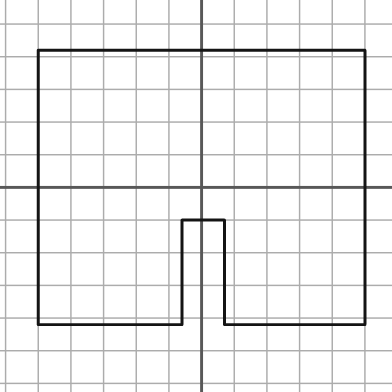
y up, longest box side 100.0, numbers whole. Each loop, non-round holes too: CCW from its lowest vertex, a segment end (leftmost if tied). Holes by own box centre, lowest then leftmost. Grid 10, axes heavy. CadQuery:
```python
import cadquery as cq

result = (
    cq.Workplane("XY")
    .moveTo(-50.0, -42.0)
    .lineTo(-6.0, -42.0)
    .lineTo(-6.0, -10.0)
    .lineTo(7.0, -10.0)
    .lineTo(7.0, -42.0)
    .lineTo(50.0, -42.0)
    .lineTo(50.0, 42.0)
    .lineTo(-50.0, 42.0)
    .close()
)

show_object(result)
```